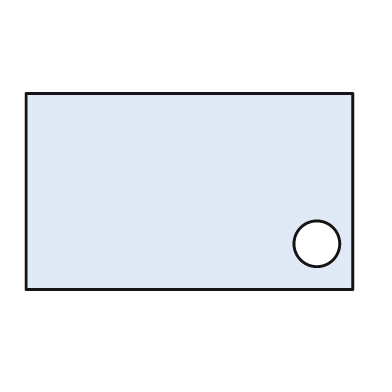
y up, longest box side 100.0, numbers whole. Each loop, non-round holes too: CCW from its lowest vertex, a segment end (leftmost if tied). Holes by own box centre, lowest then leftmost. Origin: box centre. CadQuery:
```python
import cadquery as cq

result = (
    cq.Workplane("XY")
    .moveTo(-50.0, -30.0)
    .lineTo(50.0, -30.0)
    .lineTo(50.0, 30.0)
    .lineTo(-50.0, 30.0)
    .close()
    .moveTo(39.0, -16.0)
    .circle(7.0)
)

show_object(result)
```